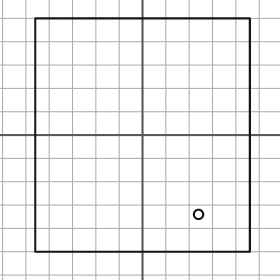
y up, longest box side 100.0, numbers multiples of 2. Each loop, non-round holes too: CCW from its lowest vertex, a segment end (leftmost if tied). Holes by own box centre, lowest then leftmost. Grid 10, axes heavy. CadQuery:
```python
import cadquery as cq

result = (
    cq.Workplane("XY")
    .moveTo(-46.0, -50.0)
    .lineTo(46.0, -50.0)
    .lineTo(46.0, 50.0)
    .lineTo(-46.0, 50.0)
    .close()
    .moveTo(24.0, -34.0)
    .circle(2.0)
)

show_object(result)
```